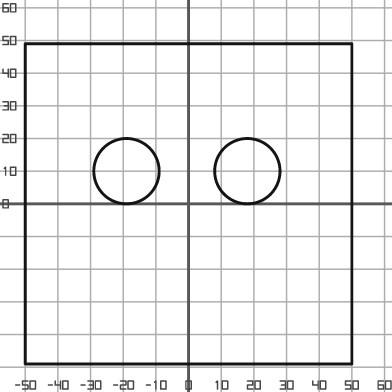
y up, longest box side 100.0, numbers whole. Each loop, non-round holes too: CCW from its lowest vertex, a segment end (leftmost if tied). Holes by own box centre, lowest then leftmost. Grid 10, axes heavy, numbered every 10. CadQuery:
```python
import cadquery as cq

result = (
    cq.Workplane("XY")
    .moveTo(-50.0, -49.0)
    .lineTo(50.0, -49.0)
    .lineTo(50.0, 49.0)
    .lineTo(-50.0, 49.0)
    .close()
    .moveTo(-19.0, 10.0)
    .circle(10.0)
    .moveTo(18.0, 10.0)
    .circle(10.0)
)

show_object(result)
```